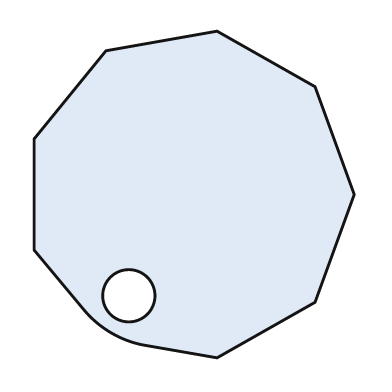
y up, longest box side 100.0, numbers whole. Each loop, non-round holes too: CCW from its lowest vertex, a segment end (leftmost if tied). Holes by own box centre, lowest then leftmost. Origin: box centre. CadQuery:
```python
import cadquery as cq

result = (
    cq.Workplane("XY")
    .moveTo(7.0, -50.0)
    .lineTo(37.0, -33.0)
    .lineTo(49.0, 0.0)
    .lineTo(37.0, 33.0)
    .lineTo(7.0, 50.0)
    .lineTo(-27.0, 44.0)
    .lineTo(-49.0, 17.0)
    .lineTo(-49.0, -17.0)
    .lineTo(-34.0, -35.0)
    .threePointArc((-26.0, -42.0), (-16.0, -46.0))
    .close()
    .moveTo(-20.0, -31.0)
    .circle(8.0)
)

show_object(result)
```